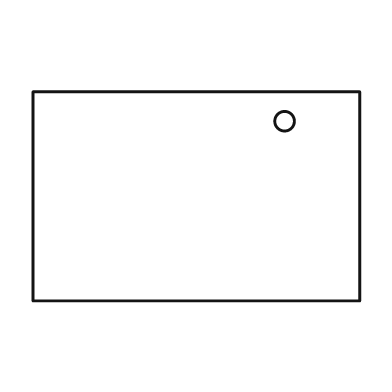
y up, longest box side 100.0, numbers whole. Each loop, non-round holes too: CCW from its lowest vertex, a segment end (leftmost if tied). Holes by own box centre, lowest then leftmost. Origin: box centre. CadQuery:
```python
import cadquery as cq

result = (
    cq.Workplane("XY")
    .moveTo(-50.0, -32.0)
    .lineTo(50.0, -32.0)
    .lineTo(50.0, 32.0)
    .lineTo(-50.0, 32.0)
    .close()
    .moveTo(27.0, 23.0)
    .circle(3.0)
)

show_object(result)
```